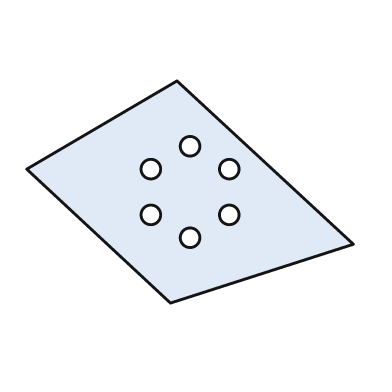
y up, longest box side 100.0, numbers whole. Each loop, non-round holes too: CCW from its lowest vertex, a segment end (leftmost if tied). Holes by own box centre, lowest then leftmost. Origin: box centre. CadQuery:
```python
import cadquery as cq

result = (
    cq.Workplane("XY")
    .moveTo(-6.0, -34.0)
    .lineTo(50.0, -16.0)
    .lineTo(-4.0, 34.0)
    .lineTo(-50.0, 7.0)
    .close()
    .moveTo(0.0, -14.0)
    .circle(3.0)
    .moveTo(-12.0, -7.0)
    .circle(3.0)
    .moveTo(12.0, -7.0)
    .circle(3.0)
    .moveTo(-12.0, 7.0)
    .circle(3.0)
    .moveTo(12.0, 7.0)
    .circle(3.0)
    .moveTo(0.0, 14.0)
    .circle(3.0)
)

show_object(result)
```